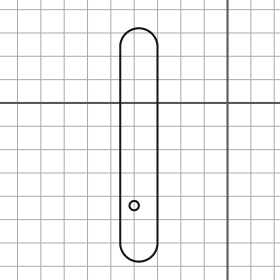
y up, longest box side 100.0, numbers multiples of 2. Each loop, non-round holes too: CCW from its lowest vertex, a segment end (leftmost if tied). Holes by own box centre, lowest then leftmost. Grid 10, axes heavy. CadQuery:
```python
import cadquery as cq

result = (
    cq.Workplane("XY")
    .moveTo(-46.0, -60.0)
    .threePointArc((-38.0, -68.0), (-30.0, -60.0))
    .lineTo(-30.0, 24.0)
    .threePointArc((-38.0, 32.0), (-46.0, 24.0))
    .close()
    .moveTo(-40.0, -44.0)
    .circle(2.0)
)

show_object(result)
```